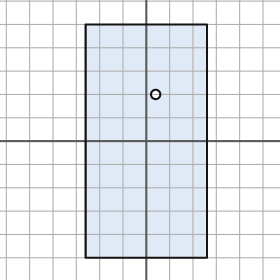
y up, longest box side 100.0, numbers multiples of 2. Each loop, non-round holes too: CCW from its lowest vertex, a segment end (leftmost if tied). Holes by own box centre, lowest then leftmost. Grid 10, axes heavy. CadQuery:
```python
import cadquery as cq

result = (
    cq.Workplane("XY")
    .moveTo(-26.0, -50.0)
    .lineTo(26.0, -50.0)
    .lineTo(26.0, 50.0)
    .lineTo(-26.0, 50.0)
    .close()
    .moveTo(4.0, 20.0)
    .circle(2.0)
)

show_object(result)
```